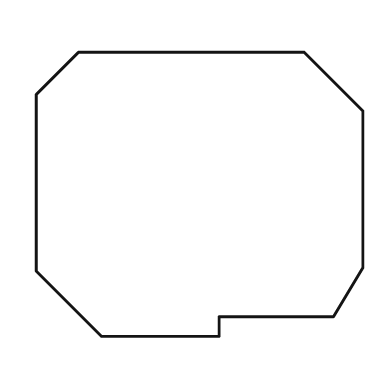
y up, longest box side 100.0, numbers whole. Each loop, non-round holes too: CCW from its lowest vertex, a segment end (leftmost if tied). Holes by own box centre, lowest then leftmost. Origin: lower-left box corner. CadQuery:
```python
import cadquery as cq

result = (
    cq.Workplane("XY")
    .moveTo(20.0, 0.0)
    .lineTo(56.0, 0.0)
    .lineTo(56.0, 6.0)
    .lineTo(91.0, 6.0)
    .lineTo(100.0, 21.0)
    .lineTo(100.0, 69.0)
    .lineTo(82.0, 87.0)
    .lineTo(13.0, 87.0)
    .lineTo(0.0, 74.0)
    .lineTo(0.0, 20.0)
    .close()
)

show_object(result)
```